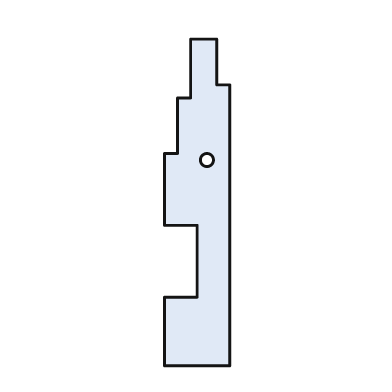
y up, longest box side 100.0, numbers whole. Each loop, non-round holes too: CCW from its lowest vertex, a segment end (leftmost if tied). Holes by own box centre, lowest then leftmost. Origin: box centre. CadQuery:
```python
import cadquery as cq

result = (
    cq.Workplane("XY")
    .moveTo(-10.0, -50.0)
    .lineTo(10.0, -50.0)
    .lineTo(10.0, 36.0)
    .lineTo(6.0, 36.0)
    .lineTo(6.0, 50.0)
    .lineTo(-2.0, 50.0)
    .lineTo(-2.0, 32.0)
    .lineTo(-6.0, 32.0)
    .lineTo(-6.0, 15.0)
    .lineTo(-10.0, 15.0)
    .lineTo(-10.0, -7.0)
    .lineTo(0.0, -7.0)
    .lineTo(0.0, -29.0)
    .lineTo(-10.0, -29.0)
    .close()
    .moveTo(3.0, 13.0)
    .circle(2.0)
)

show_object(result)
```